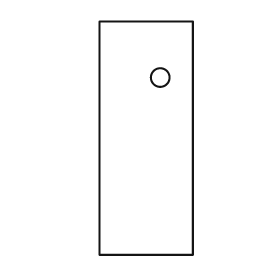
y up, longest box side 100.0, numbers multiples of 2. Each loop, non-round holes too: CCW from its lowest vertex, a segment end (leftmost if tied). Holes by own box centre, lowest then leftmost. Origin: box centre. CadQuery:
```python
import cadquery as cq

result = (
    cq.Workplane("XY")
    .moveTo(-20.0, -50.0)
    .lineTo(20.0, -50.0)
    .lineTo(20.0, 50.0)
    .lineTo(-20.0, 50.0)
    .close()
    .moveTo(6.0, 26.0)
    .circle(4.0)
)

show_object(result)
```